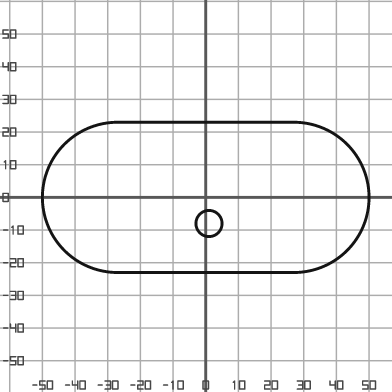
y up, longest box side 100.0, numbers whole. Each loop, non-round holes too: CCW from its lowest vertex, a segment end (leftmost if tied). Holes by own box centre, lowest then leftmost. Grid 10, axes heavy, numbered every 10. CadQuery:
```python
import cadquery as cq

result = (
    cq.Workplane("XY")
    .moveTo(-27.0, -23.0)
    .lineTo(27.0, -23.0)
    .threePointArc((50.0, 0.0), (27.0, 23.0))
    .lineTo(-27.0, 23.0)
    .threePointArc((-50.0, 0.0), (-27.0, -23.0))
    .close()
    .moveTo(1.0, -8.0)
    .circle(4.0)
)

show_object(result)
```